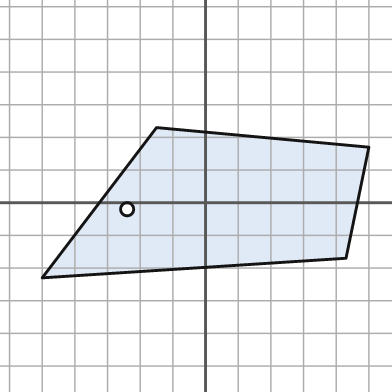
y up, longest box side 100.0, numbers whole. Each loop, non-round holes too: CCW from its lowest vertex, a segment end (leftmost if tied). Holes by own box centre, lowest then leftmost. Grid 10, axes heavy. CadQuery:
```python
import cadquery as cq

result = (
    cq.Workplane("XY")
    .moveTo(-50.0, -23.0)
    .lineTo(43.0, -17.0)
    .lineTo(50.0, 17.0)
    .lineTo(-15.0, 23.0)
    .close()
    .moveTo(-24.0, -2.0)
    .circle(2.0)
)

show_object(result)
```